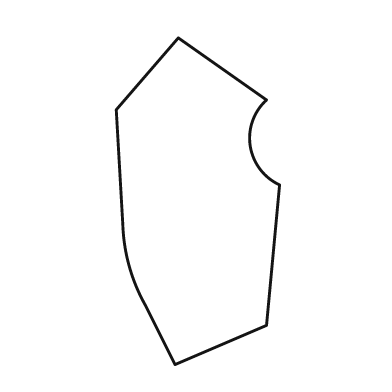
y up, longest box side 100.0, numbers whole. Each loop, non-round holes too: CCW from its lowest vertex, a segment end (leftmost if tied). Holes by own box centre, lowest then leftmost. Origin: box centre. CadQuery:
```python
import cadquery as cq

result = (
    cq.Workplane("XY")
    .moveTo(-7.0, -50.0)
    .lineTo(21.0, -38.0)
    .lineTo(25.0, 5.0)
    .threePointArc((16.0, 17.0), (21.0, 31.0))
    .lineTo(-6.0, 50.0)
    .lineTo(-25.0, 28.0)
    .lineTo(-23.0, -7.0)
    .threePointArc((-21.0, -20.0), (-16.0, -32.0))
    .close()
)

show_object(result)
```